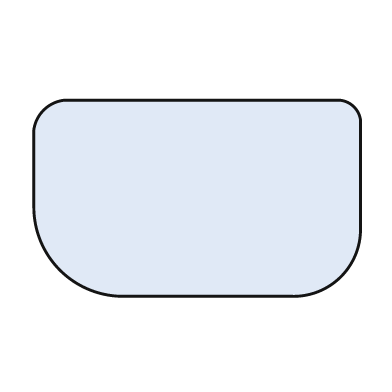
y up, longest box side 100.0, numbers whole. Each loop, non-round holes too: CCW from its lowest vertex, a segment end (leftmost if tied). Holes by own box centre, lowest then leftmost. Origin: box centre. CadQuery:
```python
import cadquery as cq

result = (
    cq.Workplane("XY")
    .moveTo(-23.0, -30.0)
    .lineTo(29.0, -30.0)
    .threePointArc((44.0, -24.0), (50.0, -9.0))
    .lineTo(50.0, 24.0)
    .threePointArc((48.0, 28.0), (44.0, 30.0))
    .lineTo(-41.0, 30.0)
    .threePointArc((-47.0, 27.0), (-50.0, 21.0))
    .lineTo(-50.0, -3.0)
    .threePointArc((-42.0, -22.0), (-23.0, -30.0))
    .close()
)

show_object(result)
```